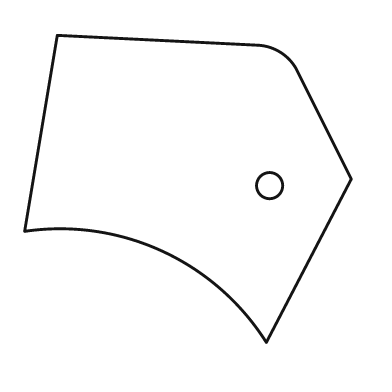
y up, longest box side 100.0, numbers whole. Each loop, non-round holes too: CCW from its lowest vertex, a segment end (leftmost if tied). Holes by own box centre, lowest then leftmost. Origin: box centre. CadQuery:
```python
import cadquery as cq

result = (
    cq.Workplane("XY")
    .moveTo(24.0, -47.0)
    .lineTo(50.0, 3.0)
    .lineTo(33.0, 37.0)
    .threePointArc((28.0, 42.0), (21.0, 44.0))
    .lineTo(-40.0, 47.0)
    .lineTo(-50.0, -13.0)
    .threePointArc((-8.0, -19.0), (24.0, -47.0))
    .close()
    .moveTo(25.0, 1.0)
    .circle(4.0)
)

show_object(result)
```